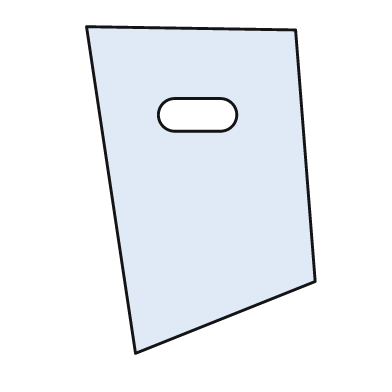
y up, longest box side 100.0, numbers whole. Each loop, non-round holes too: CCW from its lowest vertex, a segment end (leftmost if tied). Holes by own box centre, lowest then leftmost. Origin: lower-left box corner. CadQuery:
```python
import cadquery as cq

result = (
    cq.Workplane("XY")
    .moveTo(15.0, 0.0)
    .lineTo(70.0, 22.0)
    .lineTo(64.0, 99.0)
    .lineTo(0.0, 100.0)
    .close()
    .moveTo(27.0, 68.0)
    .lineTo(41.0, 68.0)
    .threePointArc((46.0, 73.0), (41.0, 78.0))
    .lineTo(27.0, 78.0)
    .threePointArc((22.0, 73.0), (27.0, 68.0))
    .close()
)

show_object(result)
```